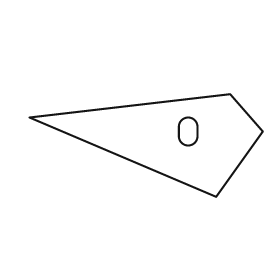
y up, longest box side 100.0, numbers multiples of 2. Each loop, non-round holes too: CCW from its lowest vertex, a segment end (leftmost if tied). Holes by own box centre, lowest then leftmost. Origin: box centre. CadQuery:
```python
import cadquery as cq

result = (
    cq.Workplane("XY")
    .moveTo(30.0, -22.0)
    .lineTo(50.0, 6.0)
    .lineTo(36.0, 22.0)
    .lineTo(-50.0, 12.0)
    .close()
    .moveTo(14.0, 4.0)
    .threePointArc((18.0, 0.0), (22.0, 4.0))
    .lineTo(22.0, 8.0)
    .threePointArc((18.0, 12.0), (14.0, 8.0))
    .close()
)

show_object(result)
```